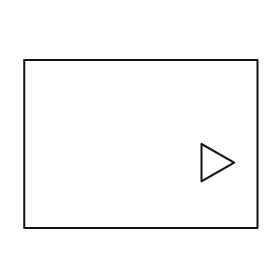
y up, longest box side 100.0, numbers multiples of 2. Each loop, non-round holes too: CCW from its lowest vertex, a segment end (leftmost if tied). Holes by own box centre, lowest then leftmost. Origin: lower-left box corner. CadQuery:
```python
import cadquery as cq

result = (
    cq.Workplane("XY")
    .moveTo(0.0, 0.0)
    .lineTo(100.0, 0.0)
    .lineTo(100.0, 72.0)
    .lineTo(0.0, 72.0)
    .close()
    .moveTo(76.0, 20.0)
    .lineTo(90.0, 28.0)
    .lineTo(76.0, 36.0)
    .close()
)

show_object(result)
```